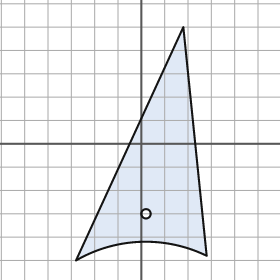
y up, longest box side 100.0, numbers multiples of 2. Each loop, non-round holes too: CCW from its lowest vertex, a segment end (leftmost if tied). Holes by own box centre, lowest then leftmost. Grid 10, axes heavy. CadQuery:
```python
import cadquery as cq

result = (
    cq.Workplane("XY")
    .moveTo(-28.0, -50.0)
    .threePointArc((0.0, -42.0), (28.0, -48.0))
    .lineTo(18.0, 50.0)
    .close()
    .moveTo(2.0, -30.0)
    .circle(2.0)
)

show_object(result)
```